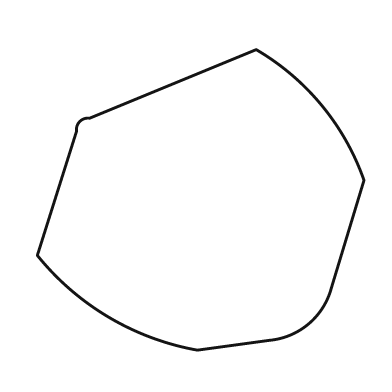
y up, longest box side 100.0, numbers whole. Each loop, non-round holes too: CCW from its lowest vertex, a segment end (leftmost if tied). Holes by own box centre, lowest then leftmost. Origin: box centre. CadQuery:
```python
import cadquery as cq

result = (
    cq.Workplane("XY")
    .moveTo(-1.0, -46.0)
    .lineTo(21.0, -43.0)
    .threePointArc((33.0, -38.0), (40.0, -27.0))
    .lineTo(50.0, 6.0)
    .threePointArc((37.0, 29.0), (17.0, 46.0))
    .lineTo(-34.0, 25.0)
    .threePointArc((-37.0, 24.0), (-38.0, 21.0))
    .lineTo(-50.0, -17.0)
    .threePointArc((-28.0, -36.0), (-1.0, -46.0))
    .close()
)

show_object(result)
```